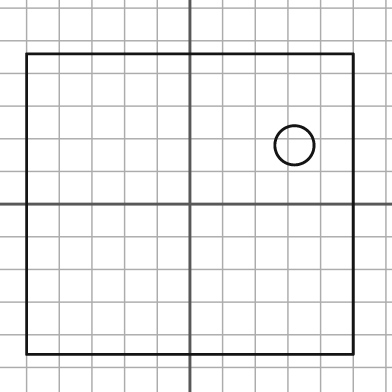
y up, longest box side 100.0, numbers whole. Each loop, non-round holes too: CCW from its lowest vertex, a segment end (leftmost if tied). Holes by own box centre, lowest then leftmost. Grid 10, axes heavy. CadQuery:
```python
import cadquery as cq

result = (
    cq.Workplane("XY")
    .moveTo(-50.0, -46.0)
    .lineTo(50.0, -46.0)
    .lineTo(50.0, 46.0)
    .lineTo(-50.0, 46.0)
    .close()
    .moveTo(32.0, 18.0)
    .circle(6.0)
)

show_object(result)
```